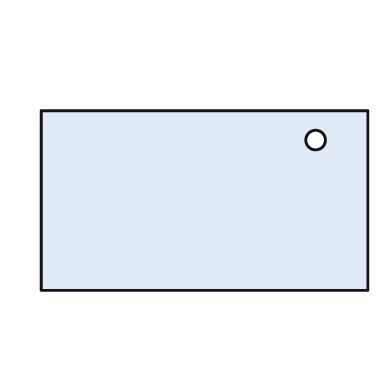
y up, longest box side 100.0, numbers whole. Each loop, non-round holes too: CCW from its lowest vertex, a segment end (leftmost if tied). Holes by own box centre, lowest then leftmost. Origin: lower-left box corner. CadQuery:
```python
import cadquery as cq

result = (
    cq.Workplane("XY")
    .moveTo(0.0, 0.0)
    .lineTo(100.0, 0.0)
    .lineTo(100.0, 55.0)
    .lineTo(0.0, 55.0)
    .close()
    .moveTo(84.0, 46.0)
    .circle(3.0)
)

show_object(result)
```